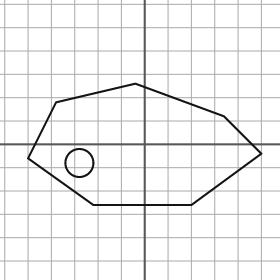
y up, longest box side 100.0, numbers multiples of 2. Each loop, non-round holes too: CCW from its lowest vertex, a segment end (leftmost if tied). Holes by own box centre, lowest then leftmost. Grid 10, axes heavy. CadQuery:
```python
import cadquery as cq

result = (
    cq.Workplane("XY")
    .moveTo(-22.0, -26.0)
    .lineTo(20.0, -26.0)
    .lineTo(50.0, -4.0)
    .lineTo(34.0, 12.0)
    .lineTo(-4.0, 26.0)
    .lineTo(-38.0, 18.0)
    .lineTo(-50.0, -6.0)
    .close()
    .moveTo(-28.0, -8.0)
    .circle(6.0)
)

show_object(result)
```